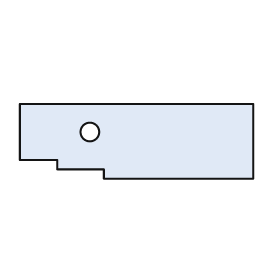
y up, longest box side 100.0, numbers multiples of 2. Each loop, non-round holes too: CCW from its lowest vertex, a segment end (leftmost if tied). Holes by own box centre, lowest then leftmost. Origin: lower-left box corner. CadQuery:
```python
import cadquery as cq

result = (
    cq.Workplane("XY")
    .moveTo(36.0, 0.0)
    .lineTo(100.0, 0.0)
    .lineTo(100.0, 32.0)
    .lineTo(0.0, 32.0)
    .lineTo(0.0, 8.0)
    .lineTo(16.0, 8.0)
    .lineTo(16.0, 4.0)
    .lineTo(36.0, 4.0)
    .close()
    .moveTo(30.0, 20.0)
    .circle(4.0)
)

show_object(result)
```